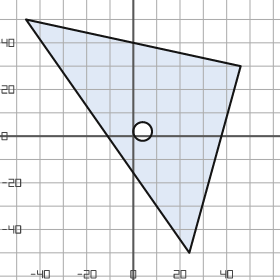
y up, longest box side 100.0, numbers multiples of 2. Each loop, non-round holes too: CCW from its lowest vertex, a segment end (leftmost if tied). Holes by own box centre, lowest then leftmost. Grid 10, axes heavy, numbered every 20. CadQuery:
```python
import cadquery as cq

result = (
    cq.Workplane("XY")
    .moveTo(24.0, -50.0)
    .lineTo(46.0, 30.0)
    .lineTo(-46.0, 50.0)
    .close()
    .moveTo(4.0, 2.0)
    .circle(4.0)
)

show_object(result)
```